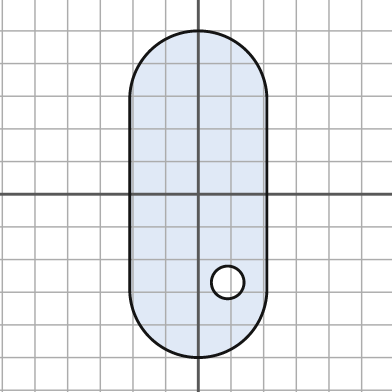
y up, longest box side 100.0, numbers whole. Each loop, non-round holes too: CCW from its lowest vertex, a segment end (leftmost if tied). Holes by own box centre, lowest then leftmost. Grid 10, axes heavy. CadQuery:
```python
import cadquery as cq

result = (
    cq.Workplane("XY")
    .moveTo(-21.0, -29.0)
    .threePointArc((0.0, -50.0), (21.0, -29.0))
    .lineTo(21.0, 29.0)
    .threePointArc((0.0, 50.0), (-21.0, 29.0))
    .close()
    .moveTo(9.0, -27.0)
    .circle(5.0)
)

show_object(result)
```